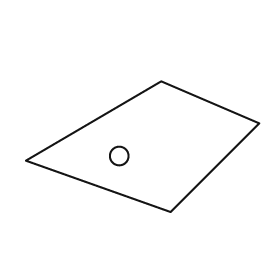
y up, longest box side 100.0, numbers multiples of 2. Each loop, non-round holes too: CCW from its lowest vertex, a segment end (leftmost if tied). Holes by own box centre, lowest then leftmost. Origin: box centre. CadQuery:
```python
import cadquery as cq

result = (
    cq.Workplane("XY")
    .moveTo(12.0, -28.0)
    .lineTo(50.0, 10.0)
    .lineTo(8.0, 28.0)
    .lineTo(-50.0, -6.0)
    .close()
    .moveTo(-10.0, -4.0)
    .circle(4.0)
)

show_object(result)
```